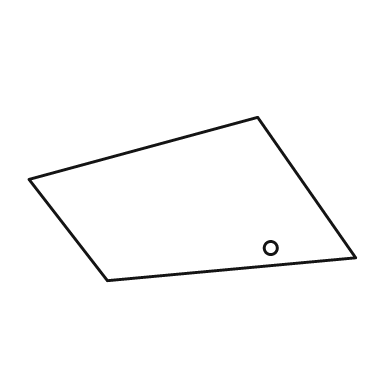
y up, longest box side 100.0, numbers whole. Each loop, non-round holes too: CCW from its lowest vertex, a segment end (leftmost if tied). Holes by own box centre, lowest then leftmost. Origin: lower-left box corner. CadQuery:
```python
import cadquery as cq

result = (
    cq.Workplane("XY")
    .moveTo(24.0, 0.0)
    .lineTo(100.0, 7.0)
    .lineTo(70.0, 50.0)
    .lineTo(0.0, 31.0)
    .close()
    .moveTo(74.0, 10.0)
    .circle(2.0)
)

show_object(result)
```